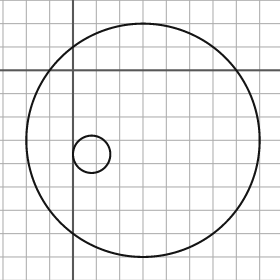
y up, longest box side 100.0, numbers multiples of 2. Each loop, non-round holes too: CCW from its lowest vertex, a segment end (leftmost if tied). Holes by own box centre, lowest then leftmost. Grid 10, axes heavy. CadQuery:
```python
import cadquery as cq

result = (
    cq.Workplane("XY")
    .moveTo(30.0, -30.0)
    .circle(50.0)
    .moveTo(8.0, -36.0)
    .circle(8.0)
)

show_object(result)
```